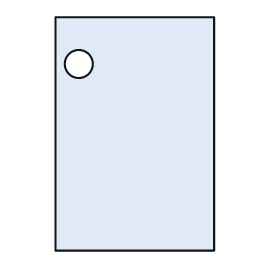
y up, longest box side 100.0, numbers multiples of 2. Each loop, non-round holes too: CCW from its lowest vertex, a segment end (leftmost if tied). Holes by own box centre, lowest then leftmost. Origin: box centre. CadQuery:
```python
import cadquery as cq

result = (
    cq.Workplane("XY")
    .moveTo(-34.0, -50.0)
    .lineTo(34.0, -50.0)
    .lineTo(34.0, 50.0)
    .lineTo(-34.0, 50.0)
    .close()
    .moveTo(-24.0, 30.0)
    .circle(6.0)
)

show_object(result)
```